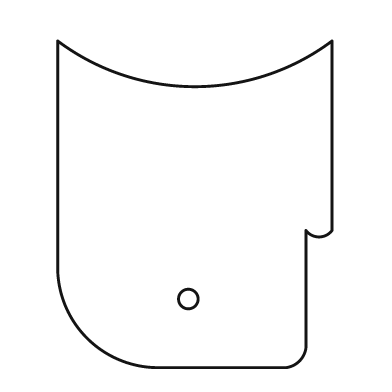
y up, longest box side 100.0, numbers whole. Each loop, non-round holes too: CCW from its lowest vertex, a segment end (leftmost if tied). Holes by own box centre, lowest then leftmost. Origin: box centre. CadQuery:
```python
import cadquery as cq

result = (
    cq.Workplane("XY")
    .moveTo(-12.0, -50.0)
    .lineTo(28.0, -50.0)
    .threePointArc((32.0, -48.0), (34.0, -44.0))
    .lineTo(34.0, -8.0)
    .threePointArc((38.0, -10.0), (42.0, -8.0))
    .lineTo(42.0, 50.0)
    .threePointArc((0.0, 36.0), (-42.0, 50.0))
    .lineTo(-42.0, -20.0)
    .threePointArc((-33.0, -41.0), (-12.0, -50.0))
    .close()
    .moveTo(-2.0, -29.0)
    .circle(3.0)
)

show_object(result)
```